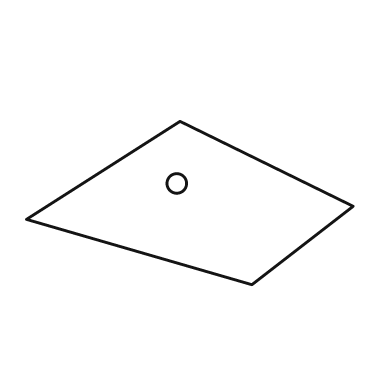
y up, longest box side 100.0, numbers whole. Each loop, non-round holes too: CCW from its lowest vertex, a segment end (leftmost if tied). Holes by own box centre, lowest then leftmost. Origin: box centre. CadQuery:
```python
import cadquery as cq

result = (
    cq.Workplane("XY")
    .moveTo(19.0, -25.0)
    .lineTo(50.0, -1.0)
    .lineTo(-3.0, 25.0)
    .lineTo(-50.0, -5.0)
    .close()
    .moveTo(-4.0, 6.0)
    .circle(3.0)
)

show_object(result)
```